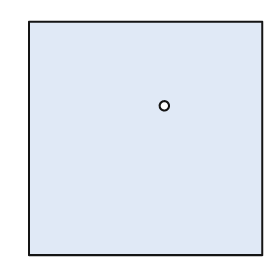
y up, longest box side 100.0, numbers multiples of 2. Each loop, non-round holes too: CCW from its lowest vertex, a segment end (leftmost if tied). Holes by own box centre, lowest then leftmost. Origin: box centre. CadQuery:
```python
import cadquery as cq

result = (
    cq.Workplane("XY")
    .moveTo(-50.0, -50.0)
    .lineTo(50.0, -50.0)
    .lineTo(50.0, 50.0)
    .lineTo(-50.0, 50.0)
    .close()
    .moveTo(8.0, 14.0)
    .circle(2.0)
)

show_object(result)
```